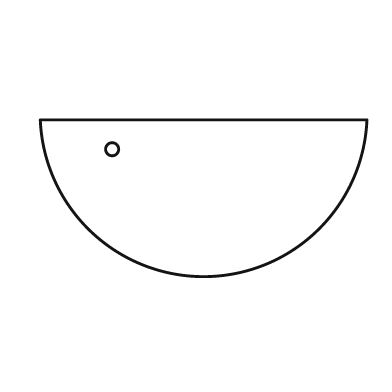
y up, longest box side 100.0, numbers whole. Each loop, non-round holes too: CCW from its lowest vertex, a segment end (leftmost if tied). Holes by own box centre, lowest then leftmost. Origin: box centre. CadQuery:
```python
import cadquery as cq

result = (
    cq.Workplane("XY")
    .moveTo(-50.0, 24.0)
    .threePointArc((0.0, -24.0), (50.0, 24.0))
    .close()
    .moveTo(-28.0, 15.0)
    .circle(2.0)
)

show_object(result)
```